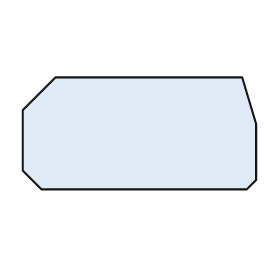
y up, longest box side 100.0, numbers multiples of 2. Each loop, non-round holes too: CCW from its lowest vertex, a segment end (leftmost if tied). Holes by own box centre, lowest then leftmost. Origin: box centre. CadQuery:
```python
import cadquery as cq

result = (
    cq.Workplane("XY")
    .moveTo(-42.0, -24.0)
    .lineTo(46.0, -24.0)
    .lineTo(50.0, -20.0)
    .lineTo(50.0, 4.0)
    .lineTo(44.0, 24.0)
    .lineTo(-36.0, 24.0)
    .lineTo(-50.0, 10.0)
    .lineTo(-50.0, -16.0)
    .close()
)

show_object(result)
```